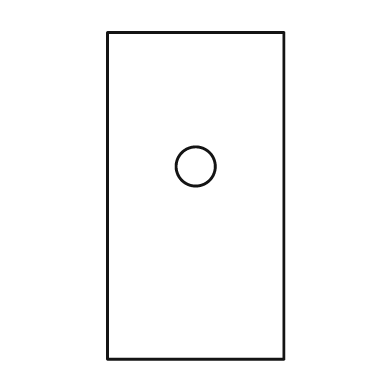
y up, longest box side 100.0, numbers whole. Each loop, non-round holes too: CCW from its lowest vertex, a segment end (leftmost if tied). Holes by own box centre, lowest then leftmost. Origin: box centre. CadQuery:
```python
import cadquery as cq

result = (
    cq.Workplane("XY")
    .moveTo(-27.0, -50.0)
    .lineTo(27.0, -50.0)
    .lineTo(27.0, 50.0)
    .lineTo(-27.0, 50.0)
    .close()
    .moveTo(0.0, 9.0)
    .circle(6.0)
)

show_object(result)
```